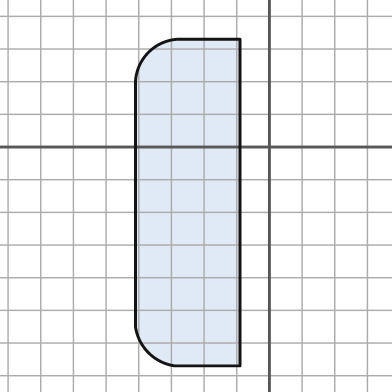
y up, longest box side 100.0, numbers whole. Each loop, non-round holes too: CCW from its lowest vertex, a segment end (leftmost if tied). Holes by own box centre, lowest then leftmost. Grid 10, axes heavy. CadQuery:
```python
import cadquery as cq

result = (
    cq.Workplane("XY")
    .moveTo(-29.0, -67.0)
    .lineTo(-9.0, -67.0)
    .lineTo(-9.0, 33.0)
    .lineTo(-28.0, 33.0)
    .threePointArc((-37.0, 29.0), (-41.0, 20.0))
    .lineTo(-41.0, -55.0)
    .threePointArc((-37.0, -63.0), (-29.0, -67.0))
    .close()
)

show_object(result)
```